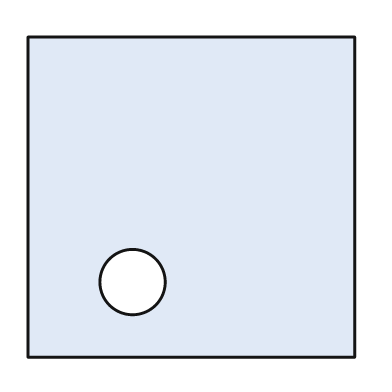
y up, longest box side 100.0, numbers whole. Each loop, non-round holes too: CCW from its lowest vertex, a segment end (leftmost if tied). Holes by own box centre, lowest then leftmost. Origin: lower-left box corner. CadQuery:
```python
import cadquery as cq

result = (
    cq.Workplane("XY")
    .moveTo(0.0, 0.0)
    .lineTo(100.0, 0.0)
    .lineTo(100.0, 98.0)
    .lineTo(0.0, 98.0)
    .close()
    .moveTo(32.0, 23.0)
    .circle(10.0)
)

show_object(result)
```